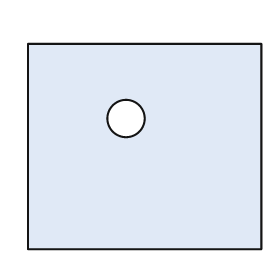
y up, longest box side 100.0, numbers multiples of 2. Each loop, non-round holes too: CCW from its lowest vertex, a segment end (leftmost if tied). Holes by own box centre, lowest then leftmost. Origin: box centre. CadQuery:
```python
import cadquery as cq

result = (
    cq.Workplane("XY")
    .moveTo(-50.0, -44.0)
    .lineTo(50.0, -44.0)
    .lineTo(50.0, 44.0)
    .lineTo(-50.0, 44.0)
    .close()
    .moveTo(-8.0, 12.0)
    .circle(8.0)
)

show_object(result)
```